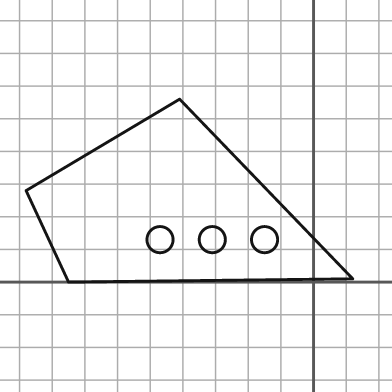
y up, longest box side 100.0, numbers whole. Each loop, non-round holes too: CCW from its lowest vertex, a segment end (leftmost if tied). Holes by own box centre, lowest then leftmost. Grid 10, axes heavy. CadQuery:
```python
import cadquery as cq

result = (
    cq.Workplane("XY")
    .moveTo(-75.0, 0.0)
    .lineTo(12.0, 1.0)
    .lineTo(-41.0, 56.0)
    .lineTo(-88.0, 28.0)
    .close()
    .moveTo(-47.0, 13.0)
    .circle(4.0)
    .moveTo(-31.0, 13.0)
    .circle(4.0)
    .moveTo(-15.0, 13.0)
    .circle(4.0)
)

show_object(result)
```